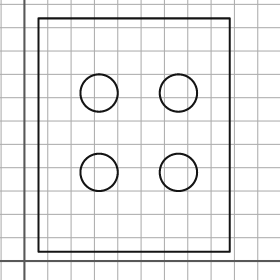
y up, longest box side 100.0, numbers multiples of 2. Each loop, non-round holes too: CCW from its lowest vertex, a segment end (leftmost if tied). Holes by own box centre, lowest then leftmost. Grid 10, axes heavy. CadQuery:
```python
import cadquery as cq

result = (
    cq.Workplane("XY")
    .moveTo(6.0, 4.0)
    .lineTo(88.0, 4.0)
    .lineTo(88.0, 104.0)
    .lineTo(6.0, 104.0)
    .close()
    .moveTo(32.0, 38.0)
    .circle(8.0)
    .moveTo(66.0, 38.0)
    .circle(8.0)
    .moveTo(32.0, 72.0)
    .circle(8.0)
    .moveTo(66.0, 72.0)
    .circle(8.0)
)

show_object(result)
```